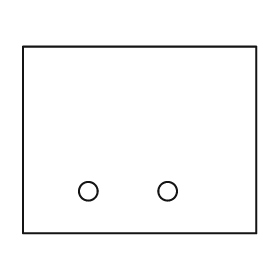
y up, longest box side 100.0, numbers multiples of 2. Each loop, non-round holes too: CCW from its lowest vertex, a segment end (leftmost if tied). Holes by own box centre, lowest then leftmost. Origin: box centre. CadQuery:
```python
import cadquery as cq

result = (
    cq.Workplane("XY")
    .moveTo(-50.0, -40.0)
    .lineTo(50.0, -40.0)
    .lineTo(50.0, 40.0)
    .lineTo(-50.0, 40.0)
    .close()
    .moveTo(-22.0, -22.0)
    .circle(4.0)
    .moveTo(12.0, -22.0)
    .circle(4.0)
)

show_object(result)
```